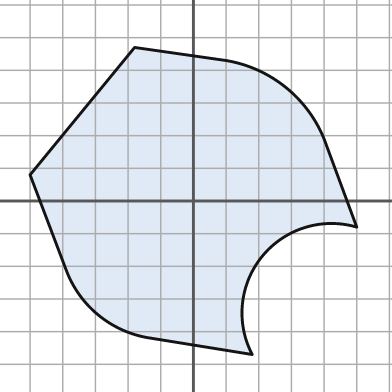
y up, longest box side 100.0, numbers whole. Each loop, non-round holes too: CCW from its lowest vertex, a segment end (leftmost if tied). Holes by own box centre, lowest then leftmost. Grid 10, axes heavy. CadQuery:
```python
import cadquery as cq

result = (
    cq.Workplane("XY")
    .moveTo(18.0, -47.0)
    .threePointArc((21.0, -17.0), (50.0, -8.0))
    .lineTo(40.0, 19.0)
    .threePointArc((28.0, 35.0), (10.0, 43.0))
    .lineTo(-18.0, 47.0)
    .lineTo(-50.0, 8.0)
    .lineTo(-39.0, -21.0)
    .threePointArc((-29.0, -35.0), (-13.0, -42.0))
    .close()
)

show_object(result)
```